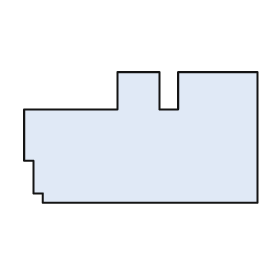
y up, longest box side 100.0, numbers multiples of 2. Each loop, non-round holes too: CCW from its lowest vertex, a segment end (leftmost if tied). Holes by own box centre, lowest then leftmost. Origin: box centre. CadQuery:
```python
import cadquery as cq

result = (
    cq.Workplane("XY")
    .moveTo(-42.0, -28.0)
    .lineTo(50.0, -28.0)
    .lineTo(50.0, 28.0)
    .lineTo(16.0, 28.0)
    .lineTo(16.0, 12.0)
    .lineTo(8.0, 12.0)
    .lineTo(8.0, 28.0)
    .lineTo(-10.0, 28.0)
    .lineTo(-10.0, 12.0)
    .lineTo(-50.0, 12.0)
    .lineTo(-50.0, -10.0)
    .lineTo(-46.0, -10.0)
    .lineTo(-46.0, -24.0)
    .lineTo(-42.0, -24.0)
    .close()
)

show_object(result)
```